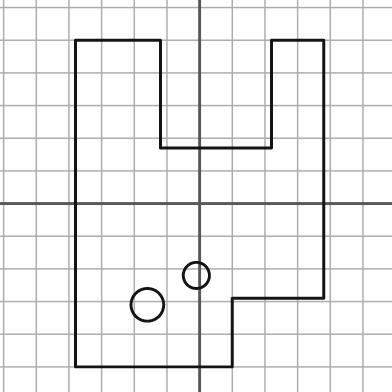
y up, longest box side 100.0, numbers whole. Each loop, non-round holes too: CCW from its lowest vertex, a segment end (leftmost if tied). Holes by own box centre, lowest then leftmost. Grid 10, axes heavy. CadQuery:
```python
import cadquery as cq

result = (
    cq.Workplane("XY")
    .moveTo(-38.0, -50.0)
    .lineTo(10.0, -50.0)
    .lineTo(10.0, -29.0)
    .lineTo(38.0, -29.0)
    .lineTo(38.0, 50.0)
    .lineTo(22.0, 50.0)
    .lineTo(22.0, 17.0)
    .lineTo(-12.0, 17.0)
    .lineTo(-12.0, 50.0)
    .lineTo(-38.0, 50.0)
    .close()
    .moveTo(-16.0, -31.0)
    .circle(5.0)
    .moveTo(-1.0, -22.0)
    .circle(4.0)
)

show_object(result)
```